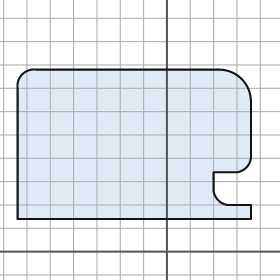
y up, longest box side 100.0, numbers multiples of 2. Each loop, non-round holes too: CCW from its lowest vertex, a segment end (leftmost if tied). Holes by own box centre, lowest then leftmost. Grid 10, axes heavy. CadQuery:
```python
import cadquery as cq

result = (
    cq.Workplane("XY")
    .moveTo(-64.0, 14.0)
    .lineTo(36.0, 14.0)
    .lineTo(36.0, 20.0)
    .lineTo(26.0, 20.0)
    .threePointArc((22.0, 22.0), (20.0, 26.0))
    .lineTo(20.0, 34.0)
    .lineTo(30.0, 34.0)
    .threePointArc((34.0, 36.0), (36.0, 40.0))
    .lineTo(36.0, 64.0)
    .threePointArc((32.0, 74.0), (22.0, 78.0))
    .lineTo(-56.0, 78.0)
    .threePointArc((-62.0, 76.0), (-64.0, 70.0))
    .close()
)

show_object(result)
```